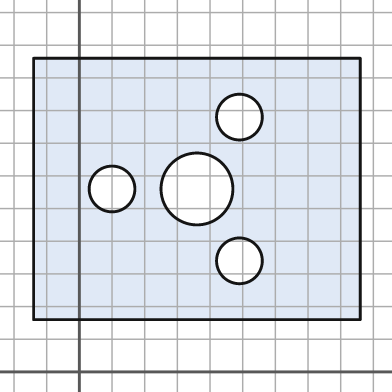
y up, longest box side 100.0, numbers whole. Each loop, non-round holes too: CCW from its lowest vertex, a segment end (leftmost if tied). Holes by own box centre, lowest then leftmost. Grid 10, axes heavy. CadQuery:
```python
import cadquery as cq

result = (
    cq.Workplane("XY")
    .moveTo(-14.0, 16.0)
    .lineTo(86.0, 16.0)
    .lineTo(86.0, 96.0)
    .lineTo(-14.0, 96.0)
    .close()
    .moveTo(49.0, 34.0)
    .circle(7.0)
    .moveTo(10.0, 56.0)
    .circle(7.0)
    .moveTo(36.0, 56.0)
    .circle(11.0)
    .moveTo(49.0, 78.0)
    .circle(7.0)
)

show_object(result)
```